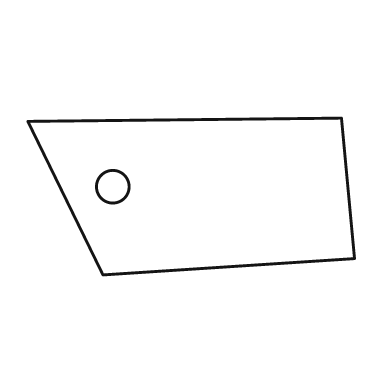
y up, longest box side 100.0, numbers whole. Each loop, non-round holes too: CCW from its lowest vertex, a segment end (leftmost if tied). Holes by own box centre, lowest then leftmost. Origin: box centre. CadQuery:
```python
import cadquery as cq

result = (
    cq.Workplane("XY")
    .moveTo(-27.0, -24.0)
    .lineTo(50.0, -19.0)
    .lineTo(46.0, 24.0)
    .lineTo(-50.0, 23.0)
    .close()
    .moveTo(-24.0, 3.0)
    .circle(5.0)
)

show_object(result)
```